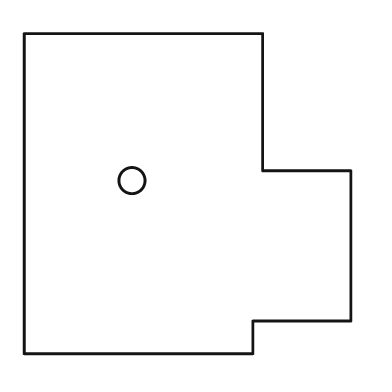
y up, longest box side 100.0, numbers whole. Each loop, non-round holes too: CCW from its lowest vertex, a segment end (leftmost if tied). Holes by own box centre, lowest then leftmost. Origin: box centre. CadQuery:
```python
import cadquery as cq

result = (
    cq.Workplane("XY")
    .moveTo(-50.0, -49.0)
    .lineTo(20.0, -49.0)
    .lineTo(20.0, -39.0)
    .lineTo(50.0, -39.0)
    .lineTo(50.0, 7.0)
    .lineTo(23.0, 7.0)
    .lineTo(23.0, 49.0)
    .lineTo(-50.0, 49.0)
    .close()
    .moveTo(-17.0, 4.0)
    .circle(4.0)
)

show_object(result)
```